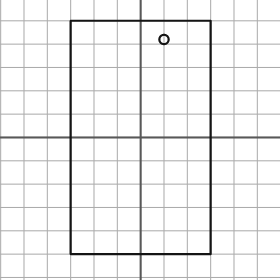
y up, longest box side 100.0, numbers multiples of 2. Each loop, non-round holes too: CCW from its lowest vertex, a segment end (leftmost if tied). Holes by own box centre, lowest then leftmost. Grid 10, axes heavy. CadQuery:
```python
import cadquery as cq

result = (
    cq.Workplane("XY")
    .moveTo(-30.0, -50.0)
    .lineTo(30.0, -50.0)
    .lineTo(30.0, 50.0)
    .lineTo(-30.0, 50.0)
    .close()
    .moveTo(10.0, 42.0)
    .circle(2.0)
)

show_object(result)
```